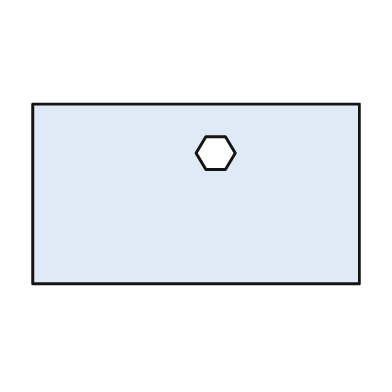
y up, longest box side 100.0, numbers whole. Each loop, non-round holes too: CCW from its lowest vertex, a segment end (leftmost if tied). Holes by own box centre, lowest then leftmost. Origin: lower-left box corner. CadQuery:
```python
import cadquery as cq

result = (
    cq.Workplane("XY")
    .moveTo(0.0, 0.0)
    .lineTo(100.0, 0.0)
    .lineTo(100.0, 55.0)
    .lineTo(0.0, 55.0)
    .close()
    .moveTo(53.0, 35.0)
    .lineTo(59.0, 35.0)
    .lineTo(62.0, 40.0)
    .lineTo(59.0, 45.0)
    .lineTo(53.0, 45.0)
    .lineTo(50.0, 40.0)
    .close()
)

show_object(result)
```